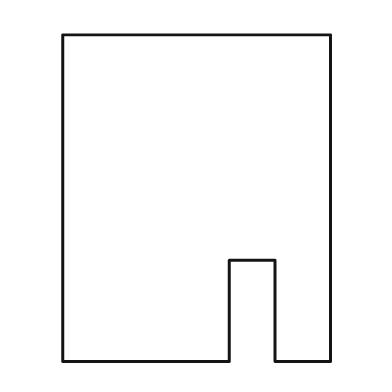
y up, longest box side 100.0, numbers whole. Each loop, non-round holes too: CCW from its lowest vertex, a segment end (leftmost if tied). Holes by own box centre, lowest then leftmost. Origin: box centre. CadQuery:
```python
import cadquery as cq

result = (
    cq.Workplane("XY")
    .moveTo(-41.0, -50.0)
    .lineTo(10.0, -50.0)
    .lineTo(10.0, -19.0)
    .lineTo(24.0, -19.0)
    .lineTo(24.0, -50.0)
    .lineTo(41.0, -50.0)
    .lineTo(41.0, 50.0)
    .lineTo(-41.0, 50.0)
    .close()
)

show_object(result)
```